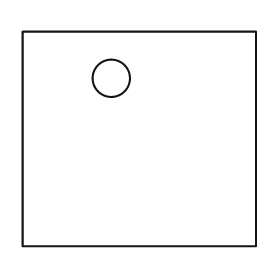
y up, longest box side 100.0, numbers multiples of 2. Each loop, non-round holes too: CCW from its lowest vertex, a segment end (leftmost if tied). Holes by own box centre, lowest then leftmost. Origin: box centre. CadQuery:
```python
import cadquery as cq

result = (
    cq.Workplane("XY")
    .moveTo(-50.0, -46.0)
    .lineTo(50.0, -46.0)
    .lineTo(50.0, 46.0)
    .lineTo(-50.0, 46.0)
    .close()
    .moveTo(-12.0, 26.0)
    .circle(8.0)
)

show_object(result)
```